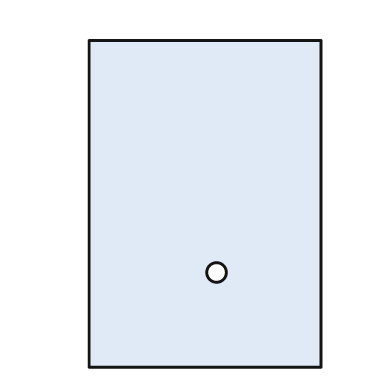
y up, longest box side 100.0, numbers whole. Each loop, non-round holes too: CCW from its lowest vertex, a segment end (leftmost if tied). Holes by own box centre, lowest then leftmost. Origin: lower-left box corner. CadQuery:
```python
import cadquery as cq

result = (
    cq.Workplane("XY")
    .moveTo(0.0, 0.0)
    .lineTo(71.0, 0.0)
    .lineTo(71.0, 100.0)
    .lineTo(0.0, 100.0)
    .close()
    .moveTo(39.0, 29.0)
    .circle(3.0)
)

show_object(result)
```